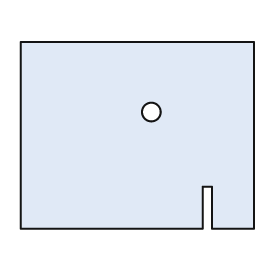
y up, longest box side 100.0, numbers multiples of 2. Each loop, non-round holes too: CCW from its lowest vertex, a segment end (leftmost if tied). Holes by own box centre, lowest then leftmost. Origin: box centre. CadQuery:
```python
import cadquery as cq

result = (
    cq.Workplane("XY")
    .moveTo(-50.0, -40.0)
    .lineTo(28.0, -40.0)
    .lineTo(28.0, -22.0)
    .lineTo(32.0, -22.0)
    .lineTo(32.0, -40.0)
    .lineTo(50.0, -40.0)
    .lineTo(50.0, 40.0)
    .lineTo(-50.0, 40.0)
    .close()
    .moveTo(6.0, 10.0)
    .circle(4.0)
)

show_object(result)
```